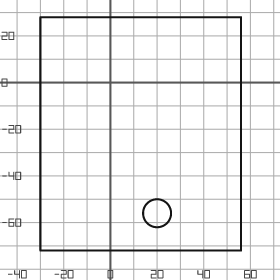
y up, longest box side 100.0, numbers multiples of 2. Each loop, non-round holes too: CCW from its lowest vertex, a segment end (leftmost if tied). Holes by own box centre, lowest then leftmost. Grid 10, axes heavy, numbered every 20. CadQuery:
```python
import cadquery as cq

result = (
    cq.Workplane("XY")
    .moveTo(-30.0, -72.0)
    .lineTo(56.0, -72.0)
    .lineTo(56.0, 28.0)
    .lineTo(-30.0, 28.0)
    .close()
    .moveTo(20.0, -56.0)
    .circle(6.0)
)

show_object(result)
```